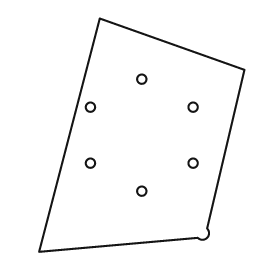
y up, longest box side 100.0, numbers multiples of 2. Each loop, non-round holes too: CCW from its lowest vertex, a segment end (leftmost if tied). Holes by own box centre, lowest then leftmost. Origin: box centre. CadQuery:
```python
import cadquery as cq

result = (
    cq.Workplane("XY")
    .moveTo(-44.0, -50.0)
    .lineTo(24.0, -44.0)
    .threePointArc((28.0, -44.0), (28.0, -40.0))
    .lineTo(44.0, 28.0)
    .lineTo(-18.0, 50.0)
    .close()
    .moveTo(0.0, -24.0)
    .circle(2.0)
    .moveTo(-22.0, -12.0)
    .circle(2.0)
    .moveTo(22.0, -12.0)
    .circle(2.0)
    .moveTo(-22.0, 12.0)
    .circle(2.0)
    .moveTo(22.0, 12.0)
    .circle(2.0)
    .moveTo(0.0, 24.0)
    .circle(2.0)
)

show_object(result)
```